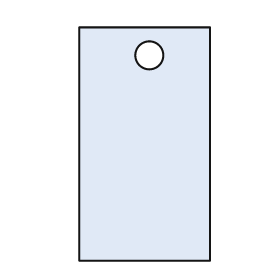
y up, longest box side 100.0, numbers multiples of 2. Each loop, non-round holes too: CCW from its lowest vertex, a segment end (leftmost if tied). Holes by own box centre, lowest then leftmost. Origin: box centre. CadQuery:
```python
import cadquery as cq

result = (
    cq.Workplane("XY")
    .moveTo(-28.0, -50.0)
    .lineTo(28.0, -50.0)
    .lineTo(28.0, 50.0)
    .lineTo(-28.0, 50.0)
    .close()
    .moveTo(2.0, 38.0)
    .circle(6.0)
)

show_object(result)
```